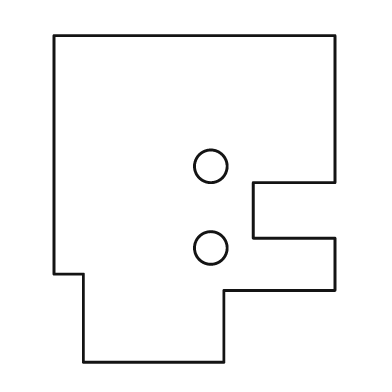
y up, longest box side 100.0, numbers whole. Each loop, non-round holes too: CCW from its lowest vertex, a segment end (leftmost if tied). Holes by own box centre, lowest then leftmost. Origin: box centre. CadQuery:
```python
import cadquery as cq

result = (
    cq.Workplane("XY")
    .moveTo(-34.0, -50.0)
    .lineTo(9.0, -50.0)
    .lineTo(9.0, -28.0)
    .lineTo(43.0, -28.0)
    .lineTo(43.0, -12.0)
    .lineTo(18.0, -12.0)
    .lineTo(18.0, 5.0)
    .lineTo(43.0, 5.0)
    .lineTo(43.0, 50.0)
    .lineTo(-43.0, 50.0)
    .lineTo(-43.0, -23.0)
    .lineTo(-34.0, -23.0)
    .close()
    .moveTo(5.0, -15.0)
    .circle(5.0)
    .moveTo(5.0, 10.0)
    .circle(5.0)
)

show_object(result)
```